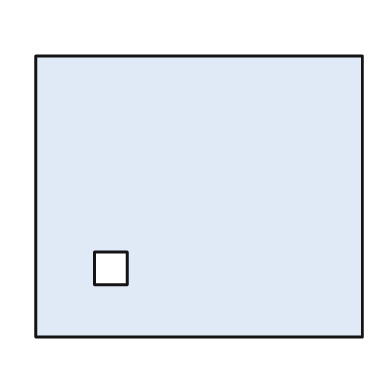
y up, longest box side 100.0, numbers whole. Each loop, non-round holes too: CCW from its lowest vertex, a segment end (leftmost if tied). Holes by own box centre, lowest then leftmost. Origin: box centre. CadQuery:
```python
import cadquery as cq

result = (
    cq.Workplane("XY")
    .moveTo(-50.0, -43.0)
    .lineTo(50.0, -43.0)
    .lineTo(50.0, 43.0)
    .lineTo(-50.0, 43.0)
    .close()
    .moveTo(-32.0, -27.0)
    .lineTo(-22.0, -27.0)
    .lineTo(-22.0, -17.0)
    .lineTo(-32.0, -17.0)
    .close()
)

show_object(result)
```